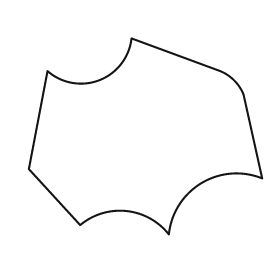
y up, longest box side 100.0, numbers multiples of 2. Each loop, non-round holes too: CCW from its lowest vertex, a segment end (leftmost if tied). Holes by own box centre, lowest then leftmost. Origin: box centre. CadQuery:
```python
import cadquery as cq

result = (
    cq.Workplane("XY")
    .moveTo(10.0, -42.0)
    .threePointArc((24.0, -20.0), (50.0, -18.0))
    .lineTo(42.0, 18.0)
    .threePointArc((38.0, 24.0), (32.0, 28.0))
    .lineTo(-6.0, 42.0)
    .threePointArc((-20.0, 24.0), (-42.0, 28.0))
    .lineTo(-50.0, -14.0)
    .lineTo(-28.0, -38.0)
    .threePointArc((-8.0, -32.0), (10.0, -42.0))
    .close()
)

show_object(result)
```